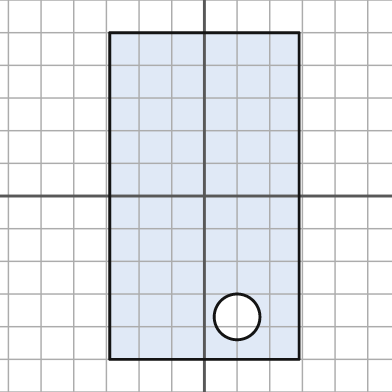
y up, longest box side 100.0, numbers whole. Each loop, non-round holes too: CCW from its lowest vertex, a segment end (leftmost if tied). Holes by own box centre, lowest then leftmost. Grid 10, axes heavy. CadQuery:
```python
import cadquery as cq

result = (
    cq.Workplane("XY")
    .moveTo(-29.0, -50.0)
    .lineTo(29.0, -50.0)
    .lineTo(29.0, 50.0)
    .lineTo(-29.0, 50.0)
    .close()
    .moveTo(10.0, -37.0)
    .circle(7.0)
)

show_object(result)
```